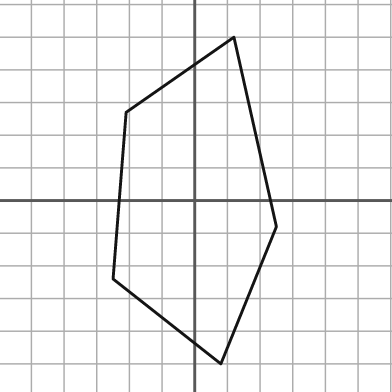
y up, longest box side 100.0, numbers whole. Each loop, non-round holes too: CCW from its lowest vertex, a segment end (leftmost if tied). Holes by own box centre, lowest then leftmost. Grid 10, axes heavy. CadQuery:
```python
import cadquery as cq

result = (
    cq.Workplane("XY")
    .moveTo(8.0, -50.0)
    .lineTo(25.0, -8.0)
    .lineTo(12.0, 50.0)
    .lineTo(-21.0, 27.0)
    .lineTo(-25.0, -24.0)
    .close()
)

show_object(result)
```